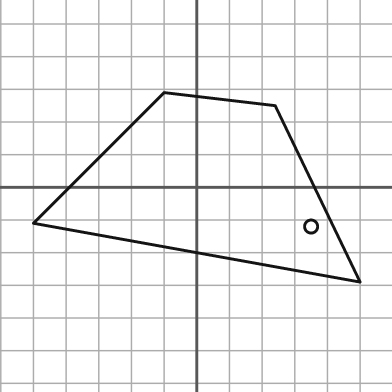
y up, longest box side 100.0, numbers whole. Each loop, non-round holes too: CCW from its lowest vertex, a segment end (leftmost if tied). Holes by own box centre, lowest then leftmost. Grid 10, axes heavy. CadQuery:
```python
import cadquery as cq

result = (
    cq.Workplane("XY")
    .moveTo(50.0, -29.0)
    .lineTo(24.0, 25.0)
    .lineTo(-10.0, 29.0)
    .lineTo(-50.0, -11.0)
    .close()
    .moveTo(35.0, -12.0)
    .circle(2.0)
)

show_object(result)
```